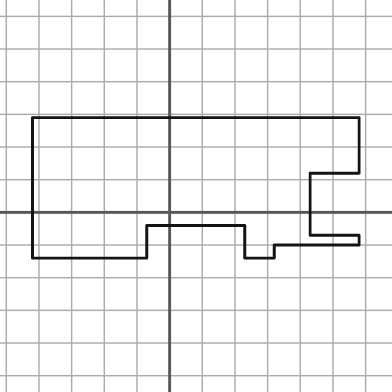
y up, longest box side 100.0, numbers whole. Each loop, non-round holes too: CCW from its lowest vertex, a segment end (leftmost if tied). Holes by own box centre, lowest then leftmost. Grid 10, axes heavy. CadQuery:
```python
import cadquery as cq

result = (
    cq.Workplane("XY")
    .moveTo(-42.0, -14.0)
    .lineTo(-7.0, -14.0)
    .lineTo(-7.0, -4.0)
    .lineTo(23.0, -4.0)
    .lineTo(23.0, -14.0)
    .lineTo(32.0, -14.0)
    .lineTo(32.0, -10.0)
    .lineTo(58.0, -10.0)
    .lineTo(58.0, -7.0)
    .lineTo(43.0, -7.0)
    .lineTo(43.0, 12.0)
    .lineTo(58.0, 12.0)
    .lineTo(58.0, 29.0)
    .lineTo(-42.0, 29.0)
    .close()
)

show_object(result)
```